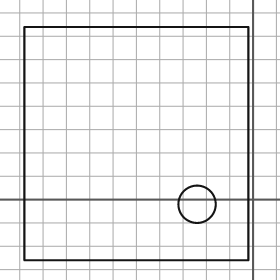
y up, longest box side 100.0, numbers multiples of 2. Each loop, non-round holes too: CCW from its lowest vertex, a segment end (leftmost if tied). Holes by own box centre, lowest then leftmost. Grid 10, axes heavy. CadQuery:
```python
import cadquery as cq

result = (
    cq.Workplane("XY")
    .moveTo(-98.0, -26.0)
    .lineTo(-2.0, -26.0)
    .lineTo(-2.0, 74.0)
    .lineTo(-98.0, 74.0)
    .close()
    .moveTo(-24.0, -2.0)
    .circle(8.0)
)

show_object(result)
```